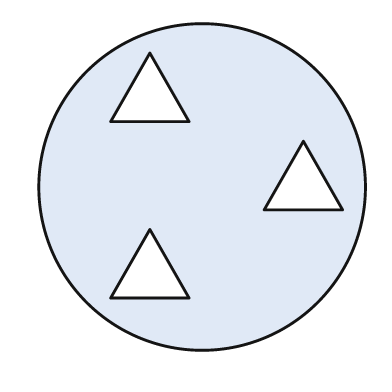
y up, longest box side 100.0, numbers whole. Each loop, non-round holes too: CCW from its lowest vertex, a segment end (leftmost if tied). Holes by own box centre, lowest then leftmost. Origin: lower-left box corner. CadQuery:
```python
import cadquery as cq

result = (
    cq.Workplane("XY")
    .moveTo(50.0, 50.0)
    .circle(50.0)
    .moveTo(22.0, 16.0)
    .lineTo(46.0, 16.0)
    .lineTo(34.0, 37.0)
    .close()
    .moveTo(69.0, 43.0)
    .lineTo(93.0, 43.0)
    .lineTo(81.0, 64.0)
    .close()
    .moveTo(22.0, 70.0)
    .lineTo(46.0, 70.0)
    .lineTo(34.0, 91.0)
    .close()
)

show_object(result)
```